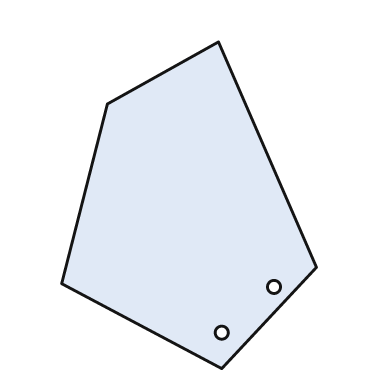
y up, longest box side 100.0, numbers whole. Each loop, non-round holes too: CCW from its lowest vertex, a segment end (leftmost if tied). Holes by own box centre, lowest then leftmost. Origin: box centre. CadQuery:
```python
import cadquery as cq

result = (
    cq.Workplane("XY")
    .moveTo(10.0, -50.0)
    .lineTo(39.0, -19.0)
    .lineTo(9.0, 50.0)
    .lineTo(-25.0, 31.0)
    .lineTo(-39.0, -24.0)
    .close()
    .moveTo(10.0, -39.0)
    .circle(2.0)
    .moveTo(26.0, -25.0)
    .circle(2.0)
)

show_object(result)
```